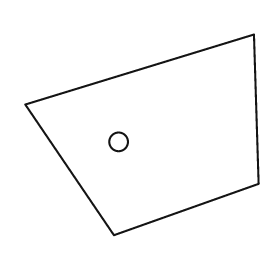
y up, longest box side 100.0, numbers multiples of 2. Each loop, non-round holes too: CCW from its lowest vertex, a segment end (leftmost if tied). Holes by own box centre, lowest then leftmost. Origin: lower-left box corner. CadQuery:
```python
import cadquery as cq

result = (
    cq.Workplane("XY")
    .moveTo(38.0, 0.0)
    .lineTo(100.0, 22.0)
    .lineTo(98.0, 86.0)
    .lineTo(0.0, 56.0)
    .close()
    .moveTo(40.0, 40.0)
    .circle(4.0)
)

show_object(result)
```